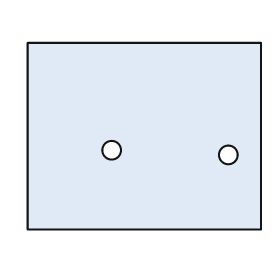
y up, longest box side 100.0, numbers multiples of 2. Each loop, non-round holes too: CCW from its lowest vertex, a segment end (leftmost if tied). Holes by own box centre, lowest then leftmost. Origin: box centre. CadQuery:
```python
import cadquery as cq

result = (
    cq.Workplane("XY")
    .moveTo(-50.0, -40.0)
    .lineTo(50.0, -40.0)
    .lineTo(50.0, 40.0)
    .lineTo(-50.0, 40.0)
    .close()
    .moveTo(36.0, -8.0)
    .circle(4.0)
    .moveTo(-14.0, -6.0)
    .circle(4.0)
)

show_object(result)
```